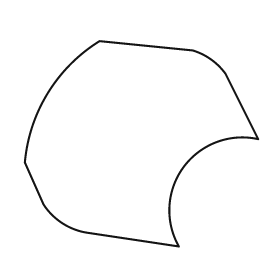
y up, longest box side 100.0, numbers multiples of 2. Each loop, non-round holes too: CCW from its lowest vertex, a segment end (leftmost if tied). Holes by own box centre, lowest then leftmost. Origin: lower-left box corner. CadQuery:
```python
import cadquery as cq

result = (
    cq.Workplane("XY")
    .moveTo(66.0, 0.0)
    .threePointArc((68.0, 34.0), (100.0, 46.0))
    .lineTo(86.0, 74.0)
    .threePointArc((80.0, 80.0), (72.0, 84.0))
    .lineTo(32.0, 88.0)
    .threePointArc((10.0, 66.0), (0.0, 36.0))
    .lineTo(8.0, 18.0)
    .threePointArc((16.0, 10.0), (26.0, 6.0))
    .close()
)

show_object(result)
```